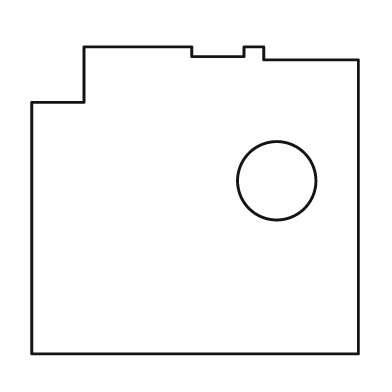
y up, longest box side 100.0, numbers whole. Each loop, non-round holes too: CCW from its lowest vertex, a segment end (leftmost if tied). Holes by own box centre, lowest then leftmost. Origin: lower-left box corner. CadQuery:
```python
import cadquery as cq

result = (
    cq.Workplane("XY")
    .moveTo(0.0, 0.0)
    .lineTo(100.0, 0.0)
    .lineTo(100.0, 90.0)
    .lineTo(71.0, 90.0)
    .lineTo(71.0, 94.0)
    .lineTo(65.0, 94.0)
    .lineTo(65.0, 91.0)
    .lineTo(49.0, 91.0)
    .lineTo(49.0, 94.0)
    .lineTo(16.0, 94.0)
    .lineTo(16.0, 77.0)
    .lineTo(0.0, 77.0)
    .close()
    .moveTo(75.0, 53.0)
    .circle(12.0)
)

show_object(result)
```